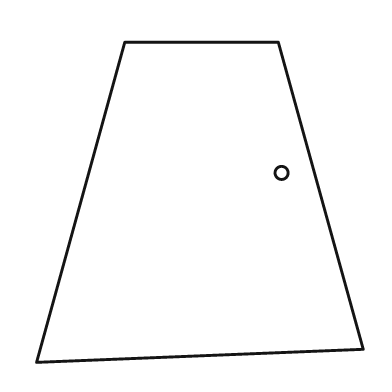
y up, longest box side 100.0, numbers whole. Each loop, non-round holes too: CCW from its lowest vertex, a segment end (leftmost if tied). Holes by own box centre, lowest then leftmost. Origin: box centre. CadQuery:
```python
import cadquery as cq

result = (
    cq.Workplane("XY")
    .moveTo(-50.0, -49.0)
    .lineTo(50.0, -45.0)
    .lineTo(24.0, 49.0)
    .lineTo(-23.0, 49.0)
    .close()
    .moveTo(25.0, 9.0)
    .circle(2.0)
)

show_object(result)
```